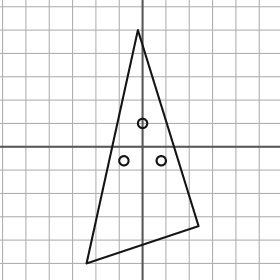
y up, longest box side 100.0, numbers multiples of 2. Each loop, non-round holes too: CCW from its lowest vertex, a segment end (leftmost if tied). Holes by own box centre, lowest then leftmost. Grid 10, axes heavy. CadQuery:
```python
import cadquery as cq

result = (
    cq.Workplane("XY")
    .moveTo(-24.0, -50.0)
    .lineTo(24.0, -34.0)
    .lineTo(-2.0, 50.0)
    .close()
    .moveTo(-8.0, -6.0)
    .circle(2.0)
    .moveTo(8.0, -6.0)
    .circle(2.0)
    .moveTo(0.0, 10.0)
    .circle(2.0)
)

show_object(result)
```